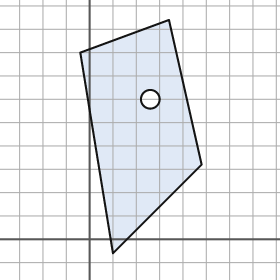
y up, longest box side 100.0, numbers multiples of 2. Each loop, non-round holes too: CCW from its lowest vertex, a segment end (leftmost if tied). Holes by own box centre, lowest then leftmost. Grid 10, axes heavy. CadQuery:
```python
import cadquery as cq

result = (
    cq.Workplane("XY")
    .moveTo(10.0, -6.0)
    .lineTo(48.0, 32.0)
    .lineTo(34.0, 94.0)
    .lineTo(-4.0, 80.0)
    .close()
    .moveTo(26.0, 60.0)
    .circle(4.0)
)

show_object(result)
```